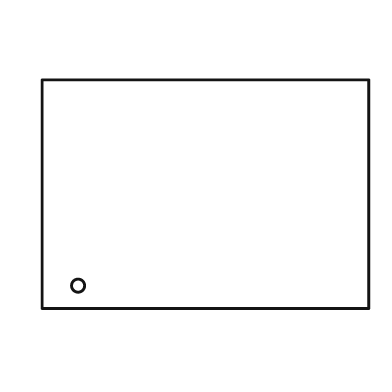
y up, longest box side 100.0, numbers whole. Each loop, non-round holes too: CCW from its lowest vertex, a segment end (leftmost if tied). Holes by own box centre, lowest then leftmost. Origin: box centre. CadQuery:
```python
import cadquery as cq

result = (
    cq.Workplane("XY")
    .moveTo(-50.0, -35.0)
    .lineTo(50.0, -35.0)
    .lineTo(50.0, 35.0)
    .lineTo(-50.0, 35.0)
    .close()
    .moveTo(-39.0, -28.0)
    .circle(2.0)
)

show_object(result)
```